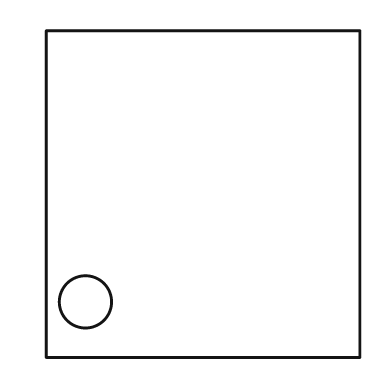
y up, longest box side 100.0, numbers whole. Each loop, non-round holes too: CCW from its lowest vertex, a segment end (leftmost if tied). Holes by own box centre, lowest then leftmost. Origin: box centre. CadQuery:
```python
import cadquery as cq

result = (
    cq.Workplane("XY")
    .moveTo(-48.0, -50.0)
    .lineTo(48.0, -50.0)
    .lineTo(48.0, 50.0)
    .lineTo(-48.0, 50.0)
    .close()
    .moveTo(-36.0, -33.0)
    .circle(8.0)
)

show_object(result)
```